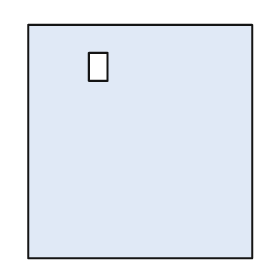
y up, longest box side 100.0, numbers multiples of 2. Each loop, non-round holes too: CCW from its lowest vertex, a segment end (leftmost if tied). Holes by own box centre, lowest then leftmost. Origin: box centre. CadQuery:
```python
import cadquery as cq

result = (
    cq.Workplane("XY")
    .moveTo(-48.0, -50.0)
    .lineTo(48.0, -50.0)
    .lineTo(48.0, 50.0)
    .lineTo(-48.0, 50.0)
    .close()
    .moveTo(-22.0, 26.0)
    .lineTo(-14.0, 26.0)
    .lineTo(-14.0, 38.0)
    .lineTo(-22.0, 38.0)
    .close()
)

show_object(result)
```